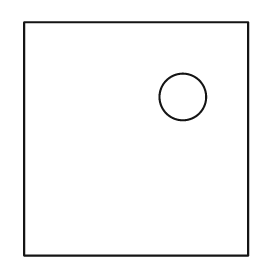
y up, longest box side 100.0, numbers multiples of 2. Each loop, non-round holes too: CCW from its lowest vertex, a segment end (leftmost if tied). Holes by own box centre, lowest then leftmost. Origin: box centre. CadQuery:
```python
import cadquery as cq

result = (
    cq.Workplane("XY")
    .moveTo(-48.0, -50.0)
    .lineTo(48.0, -50.0)
    .lineTo(48.0, 50.0)
    .lineTo(-48.0, 50.0)
    .close()
    .moveTo(20.0, 18.0)
    .circle(10.0)
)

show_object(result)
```